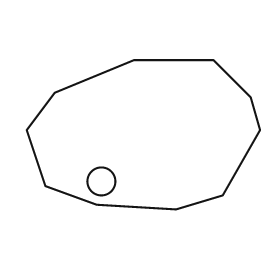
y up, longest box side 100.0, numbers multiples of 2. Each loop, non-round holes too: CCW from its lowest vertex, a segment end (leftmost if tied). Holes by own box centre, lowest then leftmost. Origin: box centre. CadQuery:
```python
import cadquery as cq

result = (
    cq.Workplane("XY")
    .moveTo(14.0, -32.0)
    .lineTo(34.0, -26.0)
    .lineTo(50.0, 2.0)
    .lineTo(46.0, 16.0)
    .lineTo(30.0, 32.0)
    .lineTo(-4.0, 32.0)
    .lineTo(-38.0, 18.0)
    .lineTo(-50.0, 2.0)
    .lineTo(-42.0, -22.0)
    .lineTo(-20.0, -30.0)
    .close()
    .moveTo(-18.0, -20.0)
    .circle(6.0)
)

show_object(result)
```